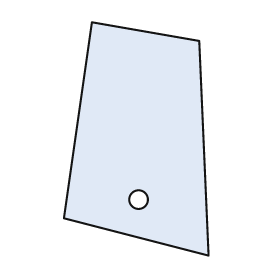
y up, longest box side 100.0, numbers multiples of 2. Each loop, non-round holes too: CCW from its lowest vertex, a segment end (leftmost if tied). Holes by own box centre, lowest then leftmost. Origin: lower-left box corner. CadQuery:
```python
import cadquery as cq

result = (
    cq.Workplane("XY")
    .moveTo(62.0, 0.0)
    .lineTo(58.0, 92.0)
    .lineTo(12.0, 100.0)
    .lineTo(0.0, 16.0)
    .close()
    .moveTo(32.0, 24.0)
    .circle(4.0)
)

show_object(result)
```